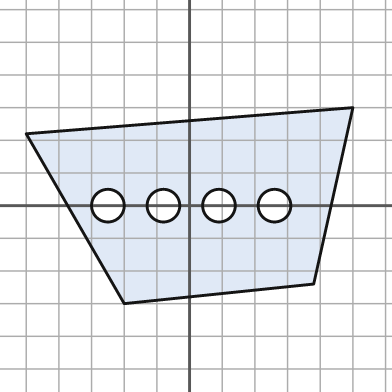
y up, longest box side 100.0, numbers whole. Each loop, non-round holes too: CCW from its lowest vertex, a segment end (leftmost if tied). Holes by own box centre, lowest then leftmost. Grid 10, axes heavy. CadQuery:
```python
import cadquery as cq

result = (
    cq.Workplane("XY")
    .moveTo(-20.0, -30.0)
    .lineTo(38.0, -24.0)
    .lineTo(50.0, 30.0)
    .lineTo(-50.0, 22.0)
    .close()
    .moveTo(-25.0, 0.0)
    .circle(5.0)
    .moveTo(-8.0, 0.0)
    .circle(5.0)
    .moveTo(9.0, 0.0)
    .circle(5.0)
    .moveTo(26.0, 0.0)
    .circle(5.0)
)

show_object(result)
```